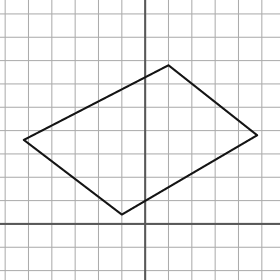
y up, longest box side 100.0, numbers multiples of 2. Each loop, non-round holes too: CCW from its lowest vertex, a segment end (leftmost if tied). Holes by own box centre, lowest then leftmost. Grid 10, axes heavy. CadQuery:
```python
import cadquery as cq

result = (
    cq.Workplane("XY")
    .moveTo(-10.0, 4.0)
    .lineTo(48.0, 38.0)
    .lineTo(10.0, 68.0)
    .lineTo(-52.0, 36.0)
    .close()
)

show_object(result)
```